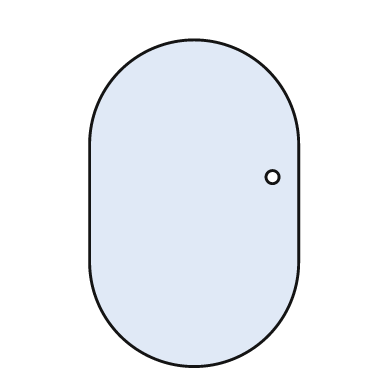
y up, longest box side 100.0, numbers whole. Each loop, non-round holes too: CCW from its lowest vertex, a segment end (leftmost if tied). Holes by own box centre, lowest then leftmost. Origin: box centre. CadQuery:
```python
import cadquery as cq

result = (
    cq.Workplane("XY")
    .moveTo(-32.0, -18.0)
    .threePointArc((0.0, -50.0), (32.0, -18.0))
    .lineTo(32.0, 18.0)
    .threePointArc((0.0, 50.0), (-32.0, 18.0))
    .close()
    .moveTo(24.0, 8.0)
    .circle(2.0)
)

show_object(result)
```